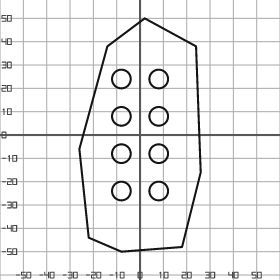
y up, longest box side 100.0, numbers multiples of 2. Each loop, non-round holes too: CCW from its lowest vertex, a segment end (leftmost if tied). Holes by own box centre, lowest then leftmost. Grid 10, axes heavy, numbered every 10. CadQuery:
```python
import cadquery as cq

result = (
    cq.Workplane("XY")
    .moveTo(-8.0, -50.0)
    .lineTo(18.0, -48.0)
    .lineTo(26.0, -16.0)
    .lineTo(24.0, 38.0)
    .lineTo(2.0, 50.0)
    .lineTo(-14.0, 38.0)
    .lineTo(-26.0, -6.0)
    .lineTo(-22.0, -44.0)
    .close()
    .moveTo(-8.0, -24.0)
    .circle(4.0)
    .moveTo(8.0, -24.0)
    .circle(4.0)
    .moveTo(-8.0, -8.0)
    .circle(4.0)
    .moveTo(8.0, -8.0)
    .circle(4.0)
    .moveTo(-8.0, 8.0)
    .circle(4.0)
    .moveTo(8.0, 8.0)
    .circle(4.0)
    .moveTo(-8.0, 24.0)
    .circle(4.0)
    .moveTo(8.0, 24.0)
    .circle(4.0)
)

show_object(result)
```